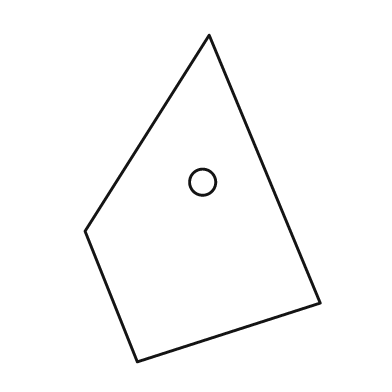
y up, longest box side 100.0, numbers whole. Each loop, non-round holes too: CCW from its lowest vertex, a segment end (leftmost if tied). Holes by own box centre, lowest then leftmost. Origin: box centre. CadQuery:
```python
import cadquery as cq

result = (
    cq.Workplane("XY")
    .moveTo(-20.0, -50.0)
    .lineTo(36.0, -32.0)
    .lineTo(2.0, 50.0)
    .lineTo(-36.0, -10.0)
    .close()
    .moveTo(0.0, 5.0)
    .circle(4.0)
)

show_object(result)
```